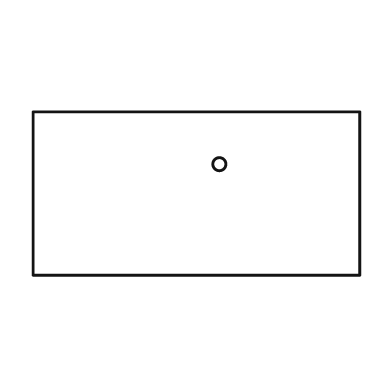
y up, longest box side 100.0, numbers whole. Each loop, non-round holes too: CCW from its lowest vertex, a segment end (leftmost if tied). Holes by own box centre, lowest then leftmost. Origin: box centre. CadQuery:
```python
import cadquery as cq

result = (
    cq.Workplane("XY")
    .moveTo(-50.0, -25.0)
    .lineTo(50.0, -25.0)
    .lineTo(50.0, 25.0)
    .lineTo(-50.0, 25.0)
    .close()
    .moveTo(7.0, 9.0)
    .circle(2.0)
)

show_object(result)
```